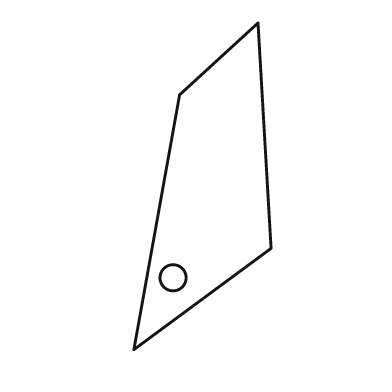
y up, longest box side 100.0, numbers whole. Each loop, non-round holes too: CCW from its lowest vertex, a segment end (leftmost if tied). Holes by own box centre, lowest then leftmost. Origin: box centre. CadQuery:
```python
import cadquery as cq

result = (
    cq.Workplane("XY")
    .moveTo(-21.0, -50.0)
    .lineTo(21.0, -19.0)
    .lineTo(17.0, 50.0)
    .lineTo(-7.0, 28.0)
    .close()
    .moveTo(-9.0, -28.0)
    .circle(4.0)
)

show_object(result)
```